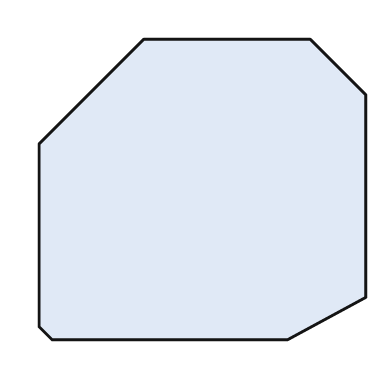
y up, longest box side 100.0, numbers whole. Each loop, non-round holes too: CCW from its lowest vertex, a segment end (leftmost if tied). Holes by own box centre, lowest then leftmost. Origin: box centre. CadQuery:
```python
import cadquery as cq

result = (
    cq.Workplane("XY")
    .moveTo(-46.0, -46.0)
    .lineTo(26.0, -46.0)
    .lineTo(50.0, -33.0)
    .lineTo(50.0, 29.0)
    .lineTo(33.0, 46.0)
    .lineTo(-18.0, 46.0)
    .lineTo(-50.0, 14.0)
    .lineTo(-50.0, -42.0)
    .close()
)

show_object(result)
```